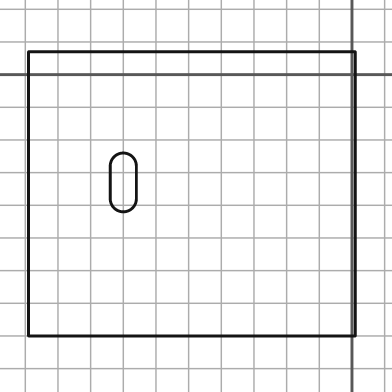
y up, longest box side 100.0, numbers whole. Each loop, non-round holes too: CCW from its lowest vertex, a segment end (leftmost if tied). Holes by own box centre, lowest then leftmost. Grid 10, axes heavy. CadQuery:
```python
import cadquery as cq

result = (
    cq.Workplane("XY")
    .moveTo(-99.0, -80.0)
    .lineTo(1.0, -80.0)
    .lineTo(1.0, 7.0)
    .lineTo(-99.0, 7.0)
    .close()
    .moveTo(-74.0, -38.0)
    .threePointArc((-70.0, -42.0), (-66.0, -38.0))
    .lineTo(-66.0, -28.0)
    .threePointArc((-70.0, -24.0), (-74.0, -28.0))
    .close()
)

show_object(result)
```